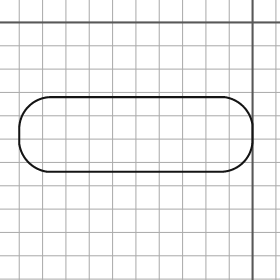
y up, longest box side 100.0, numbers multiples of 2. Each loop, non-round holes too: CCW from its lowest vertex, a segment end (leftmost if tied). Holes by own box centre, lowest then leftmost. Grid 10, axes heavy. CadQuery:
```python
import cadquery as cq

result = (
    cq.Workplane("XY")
    .moveTo(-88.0, -64.0)
    .lineTo(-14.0, -64.0)
    .threePointArc((-4.0, -60.0), (0.0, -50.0))
    .lineTo(0.0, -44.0)
    .threePointArc((-4.0, -36.0), (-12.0, -32.0))
    .lineTo(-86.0, -32.0)
    .threePointArc((-96.0, -36.0), (-100.0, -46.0))
    .lineTo(-100.0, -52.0)
    .threePointArc((-96.0, -60.0), (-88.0, -64.0))
    .close()
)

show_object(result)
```